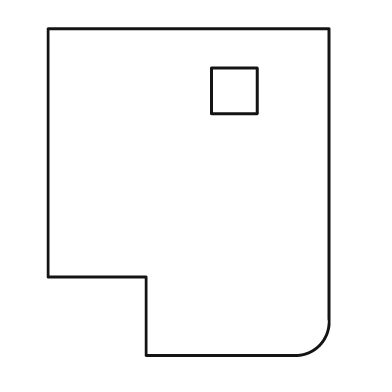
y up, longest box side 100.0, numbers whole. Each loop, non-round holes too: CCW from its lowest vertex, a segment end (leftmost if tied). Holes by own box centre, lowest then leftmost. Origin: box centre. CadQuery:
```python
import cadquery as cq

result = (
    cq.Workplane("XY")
    .moveTo(-13.0, -50.0)
    .lineTo(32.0, -50.0)
    .threePointArc((40.0, -47.0), (43.0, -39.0))
    .lineTo(43.0, 50.0)
    .lineTo(-43.0, 50.0)
    .lineTo(-43.0, -26.0)
    .lineTo(-13.0, -26.0)
    .close()
    .moveTo(7.0, 24.0)
    .lineTo(21.0, 24.0)
    .lineTo(21.0, 38.0)
    .lineTo(7.0, 38.0)
    .close()
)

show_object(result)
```